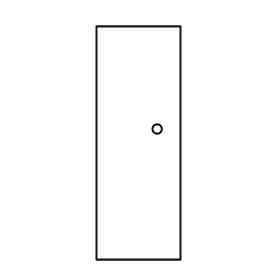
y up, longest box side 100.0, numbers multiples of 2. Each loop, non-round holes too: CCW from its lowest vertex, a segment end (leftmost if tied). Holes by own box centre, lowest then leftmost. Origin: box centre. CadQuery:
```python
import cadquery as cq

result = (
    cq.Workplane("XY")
    .moveTo(-18.0, -50.0)
    .lineTo(18.0, -50.0)
    .lineTo(18.0, 50.0)
    .lineTo(-18.0, 50.0)
    .close()
    .moveTo(8.0, 6.0)
    .circle(2.0)
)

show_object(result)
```